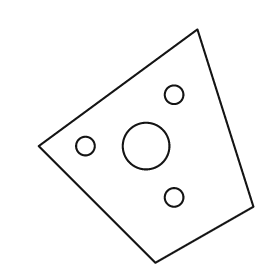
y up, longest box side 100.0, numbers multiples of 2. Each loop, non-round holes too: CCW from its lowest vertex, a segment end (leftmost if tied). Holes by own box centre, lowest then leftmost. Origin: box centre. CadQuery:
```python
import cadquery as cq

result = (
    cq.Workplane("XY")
    .moveTo(4.0, -50.0)
    .lineTo(46.0, -26.0)
    .lineTo(22.0, 50.0)
    .lineTo(-46.0, 0.0)
    .close()
    .moveTo(12.0, -22.0)
    .circle(4.0)
    .moveTo(-26.0, 0.0)
    .circle(4.0)
    .moveTo(0.0, 0.0)
    .circle(10.0)
    .moveTo(12.0, 22.0)
    .circle(4.0)
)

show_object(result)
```